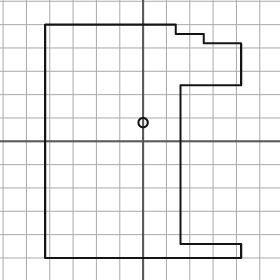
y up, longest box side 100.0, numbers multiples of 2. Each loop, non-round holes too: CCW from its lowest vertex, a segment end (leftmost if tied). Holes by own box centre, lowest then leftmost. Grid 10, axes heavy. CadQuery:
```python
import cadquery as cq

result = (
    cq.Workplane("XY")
    .moveTo(-42.0, -50.0)
    .lineTo(42.0, -50.0)
    .lineTo(42.0, -44.0)
    .lineTo(16.0, -44.0)
    .lineTo(16.0, 24.0)
    .lineTo(42.0, 24.0)
    .lineTo(42.0, 42.0)
    .lineTo(26.0, 42.0)
    .lineTo(26.0, 46.0)
    .lineTo(14.0, 46.0)
    .lineTo(14.0, 50.0)
    .lineTo(-42.0, 50.0)
    .close()
    .moveTo(0.0, 8.0)
    .circle(2.0)
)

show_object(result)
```